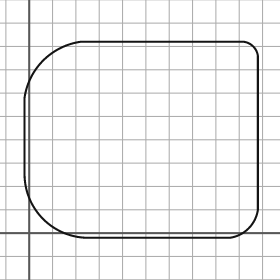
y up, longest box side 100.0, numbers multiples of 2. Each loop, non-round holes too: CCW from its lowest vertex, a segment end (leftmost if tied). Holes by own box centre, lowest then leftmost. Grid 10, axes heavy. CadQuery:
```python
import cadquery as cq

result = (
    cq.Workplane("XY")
    .moveTo(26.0, -2.0)
    .lineTo(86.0, -2.0)
    .threePointArc((94.0, 2.0), (98.0, 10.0))
    .lineTo(98.0, 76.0)
    .threePointArc((96.0, 80.0), (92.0, 82.0))
    .lineTo(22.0, 82.0)
    .threePointArc((6.0, 74.0), (-2.0, 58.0))
    .lineTo(-2.0, 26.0)
    .threePointArc((6.0, 6.0), (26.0, -2.0))
    .close()
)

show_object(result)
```